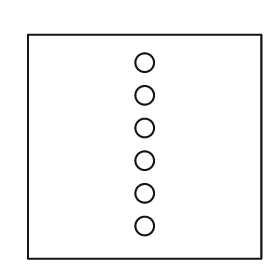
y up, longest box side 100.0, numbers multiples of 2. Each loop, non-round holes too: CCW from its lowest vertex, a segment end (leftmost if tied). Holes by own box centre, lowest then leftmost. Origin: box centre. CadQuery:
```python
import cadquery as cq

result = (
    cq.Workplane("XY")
    .moveTo(-50.0, -48.0)
    .lineTo(50.0, -48.0)
    .lineTo(50.0, 48.0)
    .lineTo(-50.0, 48.0)
    .close()
    .moveTo(0.0, -34.0)
    .circle(4.0)
    .moveTo(0.0, -20.0)
    .circle(4.0)
    .moveTo(0.0, -6.0)
    .circle(4.0)
    .moveTo(0.0, 8.0)
    .circle(4.0)
    .moveTo(0.0, 22.0)
    .circle(4.0)
    .moveTo(0.0, 36.0)
    .circle(4.0)
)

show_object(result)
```